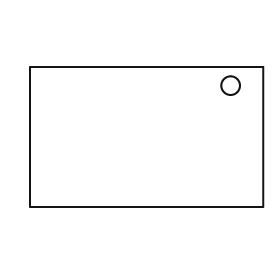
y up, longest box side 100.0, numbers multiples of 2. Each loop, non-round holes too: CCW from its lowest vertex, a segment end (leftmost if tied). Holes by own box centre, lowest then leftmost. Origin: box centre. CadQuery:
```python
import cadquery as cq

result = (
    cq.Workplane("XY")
    .moveTo(-50.0, -30.0)
    .lineTo(50.0, -30.0)
    .lineTo(50.0, 30.0)
    .lineTo(-50.0, 30.0)
    .close()
    .moveTo(36.0, 22.0)
    .circle(4.0)
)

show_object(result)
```